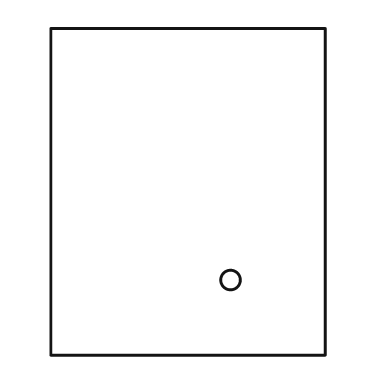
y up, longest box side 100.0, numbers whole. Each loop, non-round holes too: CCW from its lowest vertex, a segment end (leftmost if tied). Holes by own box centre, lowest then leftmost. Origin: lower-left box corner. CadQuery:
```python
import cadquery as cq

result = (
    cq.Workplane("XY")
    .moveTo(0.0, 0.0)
    .lineTo(84.0, 0.0)
    .lineTo(84.0, 100.0)
    .lineTo(0.0, 100.0)
    .close()
    .moveTo(55.0, 23.0)
    .circle(3.0)
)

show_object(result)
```